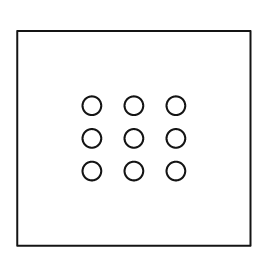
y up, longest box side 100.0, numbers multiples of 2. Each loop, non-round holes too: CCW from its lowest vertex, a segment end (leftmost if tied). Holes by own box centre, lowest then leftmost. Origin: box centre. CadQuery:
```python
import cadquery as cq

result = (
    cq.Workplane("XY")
    .moveTo(-50.0, -46.0)
    .lineTo(50.0, -46.0)
    .lineTo(50.0, 46.0)
    .lineTo(-50.0, 46.0)
    .close()
    .moveTo(-18.0, -14.0)
    .circle(4.0)
    .moveTo(0.0, -14.0)
    .circle(4.0)
    .moveTo(18.0, -14.0)
    .circle(4.0)
    .moveTo(-18.0, 0.0)
    .circle(4.0)
    .moveTo(0.0, 0.0)
    .circle(4.0)
    .moveTo(18.0, 0.0)
    .circle(4.0)
    .moveTo(-18.0, 14.0)
    .circle(4.0)
    .moveTo(0.0, 14.0)
    .circle(4.0)
    .moveTo(18.0, 14.0)
    .circle(4.0)
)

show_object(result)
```